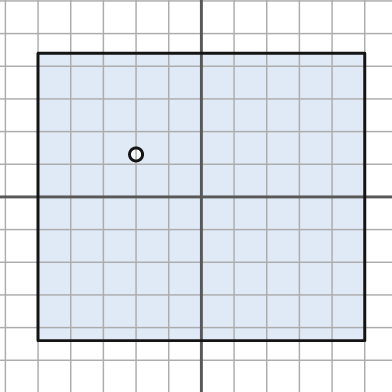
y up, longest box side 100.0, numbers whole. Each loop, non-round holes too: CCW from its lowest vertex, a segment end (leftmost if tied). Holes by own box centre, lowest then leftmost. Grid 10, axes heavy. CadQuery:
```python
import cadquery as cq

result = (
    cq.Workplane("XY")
    .moveTo(-50.0, -44.0)
    .lineTo(50.0, -44.0)
    .lineTo(50.0, 44.0)
    .lineTo(-50.0, 44.0)
    .close()
    .moveTo(-20.0, 13.0)
    .circle(2.0)
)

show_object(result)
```